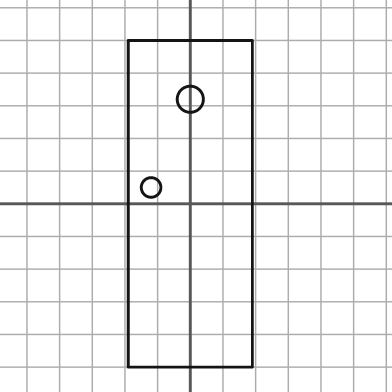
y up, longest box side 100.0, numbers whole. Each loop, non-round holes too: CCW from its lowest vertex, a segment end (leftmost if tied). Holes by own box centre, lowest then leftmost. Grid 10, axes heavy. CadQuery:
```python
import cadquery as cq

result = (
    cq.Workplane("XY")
    .moveTo(-19.0, -50.0)
    .lineTo(19.0, -50.0)
    .lineTo(19.0, 50.0)
    .lineTo(-19.0, 50.0)
    .close()
    .moveTo(-12.0, 5.0)
    .circle(3.0)
    .moveTo(0.0, 32.0)
    .circle(4.0)
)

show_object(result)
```